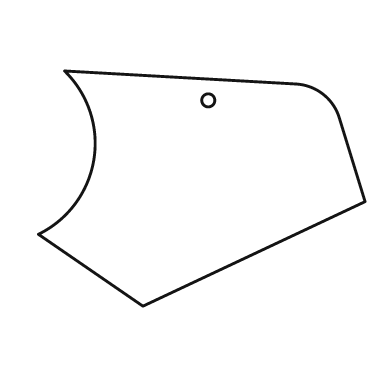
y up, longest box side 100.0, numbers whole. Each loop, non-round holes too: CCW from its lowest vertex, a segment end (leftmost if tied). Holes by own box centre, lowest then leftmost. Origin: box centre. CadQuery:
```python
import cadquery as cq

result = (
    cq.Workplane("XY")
    .moveTo(-18.0, -36.0)
    .lineTo(50.0, -4.0)
    .lineTo(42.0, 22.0)
    .threePointArc((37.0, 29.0), (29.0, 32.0))
    .lineTo(-42.0, 36.0)
    .threePointArc((-33.0, 9.0), (-50.0, -14.0))
    .close()
    .moveTo(2.0, 27.0)
    .circle(2.0)
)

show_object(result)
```